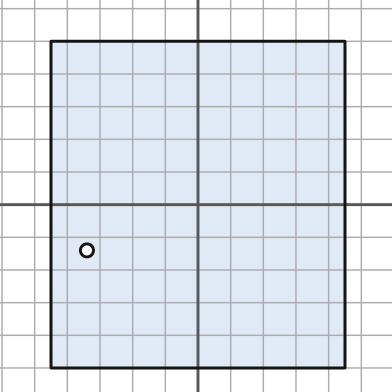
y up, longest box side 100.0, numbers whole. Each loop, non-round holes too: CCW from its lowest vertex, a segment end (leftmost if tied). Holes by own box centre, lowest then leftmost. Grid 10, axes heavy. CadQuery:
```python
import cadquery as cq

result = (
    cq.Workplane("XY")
    .moveTo(-45.0, -50.0)
    .lineTo(45.0, -50.0)
    .lineTo(45.0, 50.0)
    .lineTo(-45.0, 50.0)
    .close()
    .moveTo(-34.0, -14.0)
    .circle(2.0)
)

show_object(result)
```